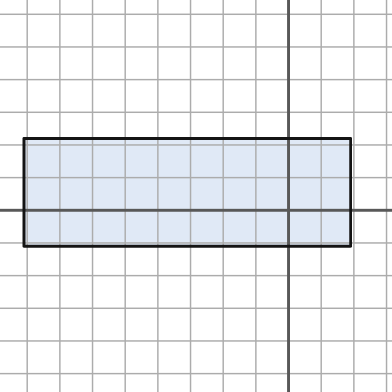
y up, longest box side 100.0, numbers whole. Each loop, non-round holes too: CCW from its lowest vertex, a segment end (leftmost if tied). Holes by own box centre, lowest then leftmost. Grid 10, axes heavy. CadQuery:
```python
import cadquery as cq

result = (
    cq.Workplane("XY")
    .moveTo(-81.0, -11.0)
    .lineTo(19.0, -11.0)
    .lineTo(19.0, 22.0)
    .lineTo(-81.0, 22.0)
    .close()
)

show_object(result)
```